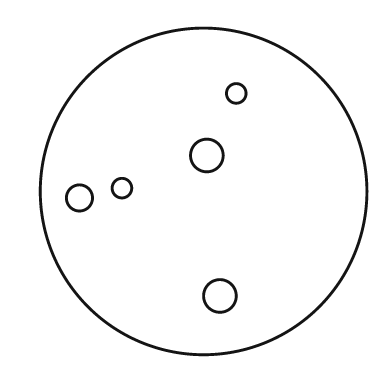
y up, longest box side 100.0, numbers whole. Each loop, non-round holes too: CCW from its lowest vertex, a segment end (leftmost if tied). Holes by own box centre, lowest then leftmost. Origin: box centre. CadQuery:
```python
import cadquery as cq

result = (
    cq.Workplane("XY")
    .moveTo(0.0, 0.0)
    .circle(50.0)
    .moveTo(5.0, -32.0)
    .circle(5.0)
    .moveTo(-38.0, -2.0)
    .circle(4.0)
    .moveTo(-25.0, 1.0)
    .circle(3.0)
    .moveTo(1.0, 11.0)
    .circle(5.0)
    .moveTo(10.0, 30.0)
    .circle(3.0)
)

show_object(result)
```